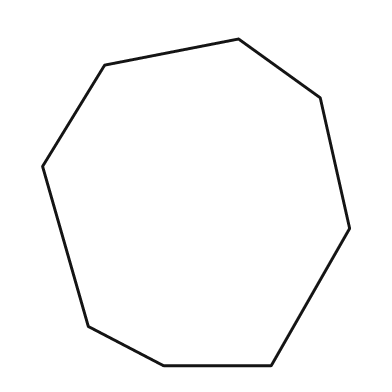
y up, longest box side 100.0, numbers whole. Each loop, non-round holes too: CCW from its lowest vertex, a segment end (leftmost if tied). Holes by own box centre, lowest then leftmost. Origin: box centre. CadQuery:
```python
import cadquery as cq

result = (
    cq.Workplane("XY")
    .moveTo(-10.0, -50.0)
    .lineTo(23.0, -50.0)
    .lineTo(47.0, -8.0)
    .lineTo(38.0, 32.0)
    .lineTo(13.0, 50.0)
    .lineTo(-28.0, 42.0)
    .lineTo(-47.0, 11.0)
    .lineTo(-33.0, -38.0)
    .close()
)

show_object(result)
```